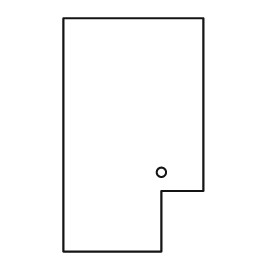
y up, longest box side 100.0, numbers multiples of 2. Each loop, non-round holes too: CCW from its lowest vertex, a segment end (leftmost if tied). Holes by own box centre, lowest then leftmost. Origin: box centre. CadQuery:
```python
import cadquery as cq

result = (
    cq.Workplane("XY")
    .moveTo(-30.0, -50.0)
    .lineTo(12.0, -50.0)
    .lineTo(12.0, -24.0)
    .lineTo(30.0, -24.0)
    .lineTo(30.0, 50.0)
    .lineTo(-30.0, 50.0)
    .close()
    .moveTo(12.0, -16.0)
    .circle(2.0)
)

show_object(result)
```